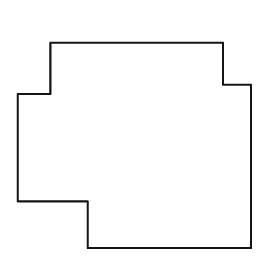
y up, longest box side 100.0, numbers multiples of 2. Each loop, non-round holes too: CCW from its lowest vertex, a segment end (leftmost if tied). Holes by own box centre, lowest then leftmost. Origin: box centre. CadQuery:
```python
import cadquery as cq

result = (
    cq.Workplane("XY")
    .moveTo(-20.0, -44.0)
    .lineTo(50.0, -44.0)
    .lineTo(50.0, 26.0)
    .lineTo(38.0, 26.0)
    .lineTo(38.0, 44.0)
    .lineTo(-36.0, 44.0)
    .lineTo(-36.0, 22.0)
    .lineTo(-50.0, 22.0)
    .lineTo(-50.0, -24.0)
    .lineTo(-20.0, -24.0)
    .close()
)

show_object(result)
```